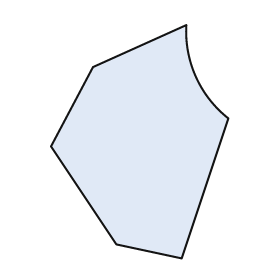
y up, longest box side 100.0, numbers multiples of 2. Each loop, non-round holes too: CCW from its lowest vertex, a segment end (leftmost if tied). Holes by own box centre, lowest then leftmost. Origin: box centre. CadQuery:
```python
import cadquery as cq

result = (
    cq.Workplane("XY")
    .moveTo(18.0, -50.0)
    .lineTo(38.0, 10.0)
    .threePointArc((24.0, 28.0), (20.0, 50.0))
    .lineTo(-20.0, 32.0)
    .lineTo(-38.0, -2.0)
    .lineTo(-10.0, -44.0)
    .close()
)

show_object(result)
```